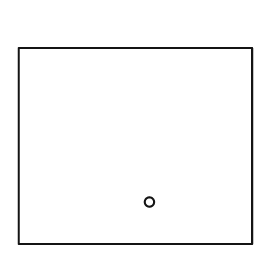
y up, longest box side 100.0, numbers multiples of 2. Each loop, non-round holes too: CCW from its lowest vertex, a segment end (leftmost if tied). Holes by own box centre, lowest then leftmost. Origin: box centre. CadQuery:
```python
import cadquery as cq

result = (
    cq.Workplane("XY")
    .moveTo(-50.0, -42.0)
    .lineTo(50.0, -42.0)
    .lineTo(50.0, 42.0)
    .lineTo(-50.0, 42.0)
    .close()
    .moveTo(6.0, -24.0)
    .circle(2.0)
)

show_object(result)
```